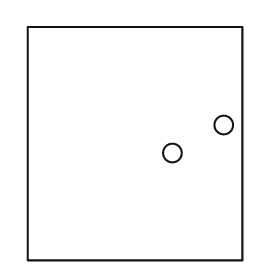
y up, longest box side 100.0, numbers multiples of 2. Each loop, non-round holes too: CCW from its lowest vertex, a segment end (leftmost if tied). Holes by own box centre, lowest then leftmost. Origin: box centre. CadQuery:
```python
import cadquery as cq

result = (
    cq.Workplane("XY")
    .moveTo(-46.0, -50.0)
    .lineTo(46.0, -50.0)
    .lineTo(46.0, 50.0)
    .lineTo(-46.0, 50.0)
    .close()
    .moveTo(16.0, -4.0)
    .circle(4.0)
    .moveTo(38.0, 8.0)
    .circle(4.0)
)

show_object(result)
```